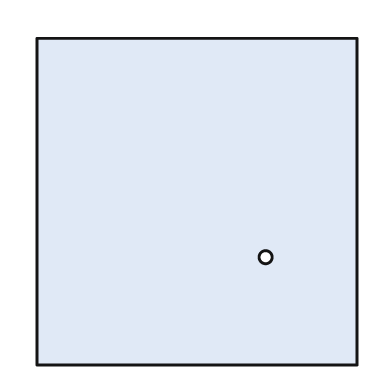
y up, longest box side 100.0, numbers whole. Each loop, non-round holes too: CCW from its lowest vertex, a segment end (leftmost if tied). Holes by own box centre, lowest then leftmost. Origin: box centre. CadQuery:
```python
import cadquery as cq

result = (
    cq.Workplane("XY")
    .moveTo(-49.0, -50.0)
    .lineTo(49.0, -50.0)
    .lineTo(49.0, 50.0)
    .lineTo(-49.0, 50.0)
    .close()
    .moveTo(21.0, -17.0)
    .circle(2.0)
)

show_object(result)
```